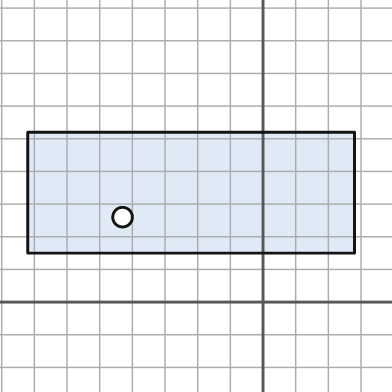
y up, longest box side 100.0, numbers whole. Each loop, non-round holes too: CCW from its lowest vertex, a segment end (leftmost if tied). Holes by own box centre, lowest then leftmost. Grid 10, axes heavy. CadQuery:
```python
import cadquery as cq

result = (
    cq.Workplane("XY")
    .moveTo(-72.0, 15.0)
    .lineTo(28.0, 15.0)
    .lineTo(28.0, 52.0)
    .lineTo(-72.0, 52.0)
    .close()
    .moveTo(-43.0, 26.0)
    .circle(3.0)
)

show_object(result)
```